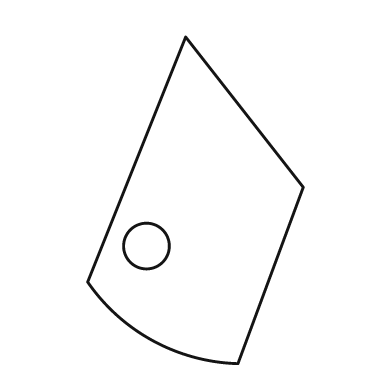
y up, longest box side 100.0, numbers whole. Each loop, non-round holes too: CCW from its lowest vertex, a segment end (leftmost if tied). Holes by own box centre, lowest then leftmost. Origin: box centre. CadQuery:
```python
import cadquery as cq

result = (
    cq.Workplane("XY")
    .moveTo(13.0, -50.0)
    .lineTo(33.0, 4.0)
    .lineTo(-3.0, 50.0)
    .lineTo(-33.0, -25.0)
    .threePointArc((-13.0, -43.0), (13.0, -50.0))
    .close()
    .moveTo(-15.0, -14.0)
    .circle(7.0)
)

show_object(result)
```